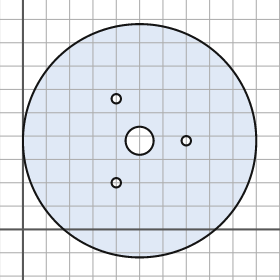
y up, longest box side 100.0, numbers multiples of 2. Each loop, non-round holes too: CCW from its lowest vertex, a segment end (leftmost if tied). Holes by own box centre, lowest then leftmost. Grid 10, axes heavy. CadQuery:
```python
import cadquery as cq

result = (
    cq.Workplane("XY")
    .moveTo(50.0, 38.0)
    .circle(50.0)
    .moveTo(40.0, 20.0)
    .circle(2.0)
    .moveTo(50.0, 38.0)
    .circle(6.0)
    .moveTo(70.0, 38.0)
    .circle(2.0)
    .moveTo(40.0, 56.0)
    .circle(2.0)
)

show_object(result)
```